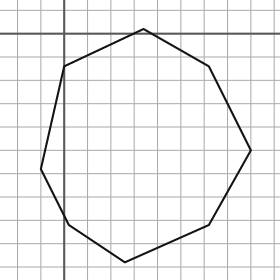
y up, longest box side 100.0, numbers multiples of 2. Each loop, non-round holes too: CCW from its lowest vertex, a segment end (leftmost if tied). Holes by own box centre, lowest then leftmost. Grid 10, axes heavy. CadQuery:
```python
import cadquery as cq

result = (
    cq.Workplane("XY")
    .moveTo(26.0, -98.0)
    .lineTo(62.0, -82.0)
    .lineTo(80.0, -50.0)
    .lineTo(62.0, -14.0)
    .lineTo(34.0, 2.0)
    .lineTo(0.0, -14.0)
    .lineTo(-10.0, -58.0)
    .lineTo(2.0, -82.0)
    .close()
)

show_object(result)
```